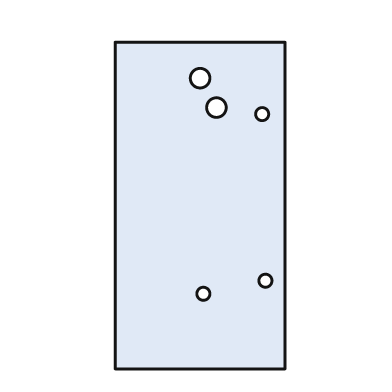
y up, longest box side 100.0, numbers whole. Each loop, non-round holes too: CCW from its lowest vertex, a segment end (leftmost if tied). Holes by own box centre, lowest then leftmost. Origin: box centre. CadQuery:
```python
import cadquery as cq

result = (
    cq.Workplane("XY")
    .moveTo(-26.0, -50.0)
    .lineTo(26.0, -50.0)
    .lineTo(26.0, 50.0)
    .lineTo(-26.0, 50.0)
    .close()
    .moveTo(1.0, -27.0)
    .circle(2.0)
    .moveTo(20.0, -23.0)
    .circle(2.0)
    .moveTo(19.0, 28.0)
    .circle(2.0)
    .moveTo(5.0, 30.0)
    .circle(3.0)
    .moveTo(0.0, 39.0)
    .circle(3.0)
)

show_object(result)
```